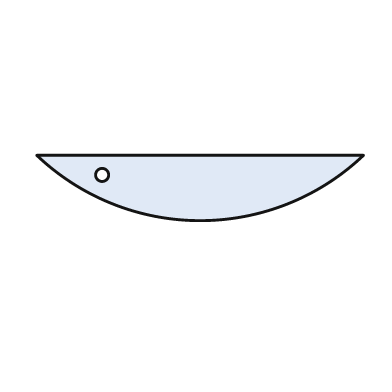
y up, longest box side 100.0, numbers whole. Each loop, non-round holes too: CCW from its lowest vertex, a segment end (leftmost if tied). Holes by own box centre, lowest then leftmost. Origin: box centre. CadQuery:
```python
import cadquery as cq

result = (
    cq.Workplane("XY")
    .moveTo(-50.0, 10.0)
    .threePointArc((0.0, -10.0), (50.0, 10.0))
    .close()
    .moveTo(-30.0, 4.0)
    .circle(2.0)
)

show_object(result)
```